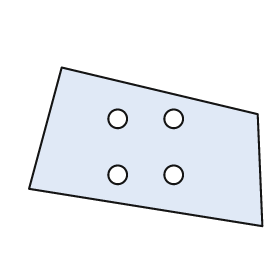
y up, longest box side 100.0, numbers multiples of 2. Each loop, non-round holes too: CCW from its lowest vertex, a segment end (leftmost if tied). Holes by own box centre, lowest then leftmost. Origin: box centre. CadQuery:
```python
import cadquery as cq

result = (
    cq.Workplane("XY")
    .moveTo(50.0, -34.0)
    .lineTo(48.0, 14.0)
    .lineTo(-36.0, 34.0)
    .lineTo(-50.0, -18.0)
    .close()
    .moveTo(-12.0, -12.0)
    .circle(4.0)
    .moveTo(12.0, -12.0)
    .circle(4.0)
    .moveTo(-12.0, 12.0)
    .circle(4.0)
    .moveTo(12.0, 12.0)
    .circle(4.0)
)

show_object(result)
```